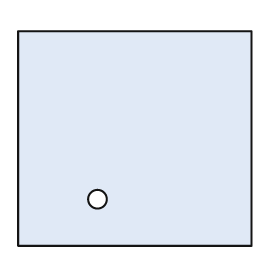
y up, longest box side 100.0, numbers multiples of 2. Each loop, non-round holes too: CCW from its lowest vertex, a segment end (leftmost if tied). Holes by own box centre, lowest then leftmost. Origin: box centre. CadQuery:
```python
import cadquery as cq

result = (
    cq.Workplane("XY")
    .moveTo(-50.0, -46.0)
    .lineTo(50.0, -46.0)
    .lineTo(50.0, 46.0)
    .lineTo(-50.0, 46.0)
    .close()
    .moveTo(-16.0, -26.0)
    .circle(4.0)
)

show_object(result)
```